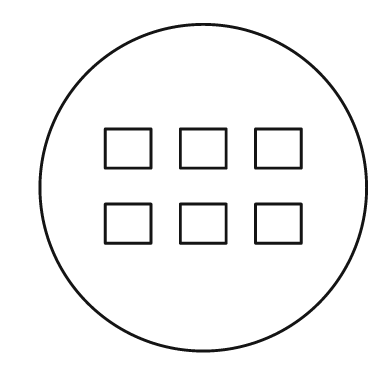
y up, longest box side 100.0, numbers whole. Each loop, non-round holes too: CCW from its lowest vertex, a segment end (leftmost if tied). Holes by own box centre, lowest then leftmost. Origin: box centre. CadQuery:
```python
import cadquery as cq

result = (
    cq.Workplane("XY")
    .moveTo(0.0, 0.0)
    .circle(50.0)
    .moveTo(-30.0, -17.0)
    .lineTo(-16.0, -17.0)
    .lineTo(-16.0, -5.0)
    .lineTo(-30.0, -5.0)
    .close()
    .moveTo(-7.0, -17.0)
    .lineTo(7.0, -17.0)
    .lineTo(7.0, -5.0)
    .lineTo(-7.0, -5.0)
    .close()
    .moveTo(16.0, -17.0)
    .lineTo(30.0, -17.0)
    .lineTo(30.0, -5.0)
    .lineTo(16.0, -5.0)
    .close()
    .moveTo(-30.0, 6.0)
    .lineTo(-16.0, 6.0)
    .lineTo(-16.0, 18.0)
    .lineTo(-30.0, 18.0)
    .close()
    .moveTo(-7.0, 6.0)
    .lineTo(7.0, 6.0)
    .lineTo(7.0, 18.0)
    .lineTo(-7.0, 18.0)
    .close()
    .moveTo(16.0, 6.0)
    .lineTo(30.0, 6.0)
    .lineTo(30.0, 18.0)
    .lineTo(16.0, 18.0)
    .close()
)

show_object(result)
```